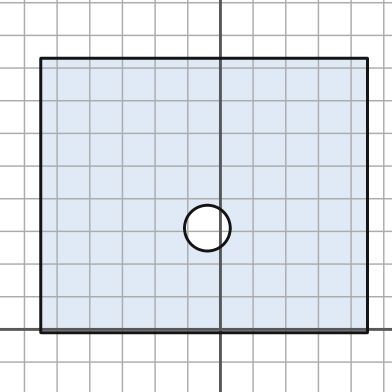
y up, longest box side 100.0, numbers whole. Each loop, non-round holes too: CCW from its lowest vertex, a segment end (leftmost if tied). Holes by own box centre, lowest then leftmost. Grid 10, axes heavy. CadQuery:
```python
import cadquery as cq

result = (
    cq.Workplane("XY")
    .moveTo(-55.0, -1.0)
    .lineTo(45.0, -1.0)
    .lineTo(45.0, 83.0)
    .lineTo(-55.0, 83.0)
    .close()
    .moveTo(-4.0, 31.0)
    .circle(7.0)
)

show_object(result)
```